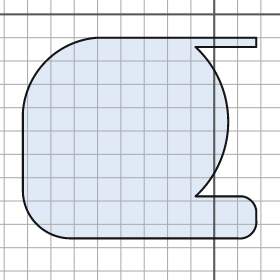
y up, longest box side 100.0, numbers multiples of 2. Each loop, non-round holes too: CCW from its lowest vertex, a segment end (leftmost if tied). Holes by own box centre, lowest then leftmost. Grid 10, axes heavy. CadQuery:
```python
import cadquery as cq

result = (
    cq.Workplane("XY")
    .moveTo(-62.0, -96.0)
    .lineTo(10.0, -96.0)
    .threePointArc((16.0, -94.0), (18.0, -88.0))
    .lineTo(18.0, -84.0)
    .threePointArc((16.0, -80.0), (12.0, -78.0))
    .lineTo(-8.0, -78.0)
    .threePointArc((6.0, -46.0), (-8.0, -14.0))
    .lineTo(18.0, -14.0)
    .lineTo(18.0, -10.0)
    .lineTo(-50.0, -10.0)
    .threePointArc((-72.0, -20.0), (-82.0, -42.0))
    .lineTo(-82.0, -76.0)
    .threePointArc((-76.0, -90.0), (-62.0, -96.0))
    .close()
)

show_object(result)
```